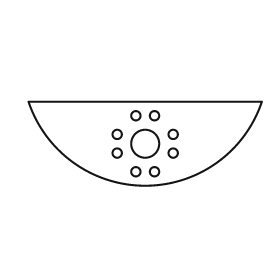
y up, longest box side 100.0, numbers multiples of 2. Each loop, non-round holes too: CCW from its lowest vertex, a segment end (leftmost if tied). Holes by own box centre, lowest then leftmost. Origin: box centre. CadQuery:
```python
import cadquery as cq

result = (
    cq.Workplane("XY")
    .moveTo(-50.0, 18.0)
    .threePointArc((0.0, -18.0), (50.0, 18.0))
    .close()
    .moveTo(-4.0, -12.0)
    .circle(2.0)
    .moveTo(4.0, -12.0)
    .circle(2.0)
    .moveTo(-12.0, -4.0)
    .circle(2.0)
    .moveTo(12.0, -4.0)
    .circle(2.0)
    .moveTo(0.0, 0.0)
    .circle(6.0)
    .moveTo(-12.0, 4.0)
    .circle(2.0)
    .moveTo(12.0, 4.0)
    .circle(2.0)
    .moveTo(-4.0, 12.0)
    .circle(2.0)
    .moveTo(4.0, 12.0)
    .circle(2.0)
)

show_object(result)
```